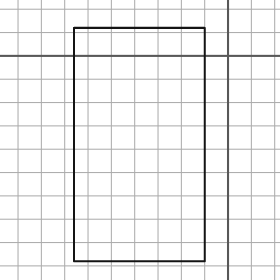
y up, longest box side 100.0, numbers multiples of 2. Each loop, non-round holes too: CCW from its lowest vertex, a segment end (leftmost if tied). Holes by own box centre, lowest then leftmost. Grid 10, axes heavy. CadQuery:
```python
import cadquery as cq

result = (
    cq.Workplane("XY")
    .moveTo(-66.0, -88.0)
    .lineTo(-10.0, -88.0)
    .lineTo(-10.0, 12.0)
    .lineTo(-66.0, 12.0)
    .close()
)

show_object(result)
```